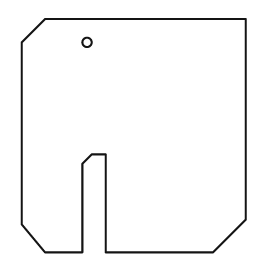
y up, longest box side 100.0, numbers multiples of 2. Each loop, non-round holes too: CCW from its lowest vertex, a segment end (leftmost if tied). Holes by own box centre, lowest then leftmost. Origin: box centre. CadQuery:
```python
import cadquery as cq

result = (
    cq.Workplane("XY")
    .moveTo(-38.0, -50.0)
    .lineTo(-22.0, -50.0)
    .lineTo(-22.0, -12.0)
    .lineTo(-18.0, -8.0)
    .lineTo(-12.0, -8.0)
    .lineTo(-12.0, -50.0)
    .lineTo(34.0, -50.0)
    .lineTo(48.0, -36.0)
    .lineTo(48.0, 50.0)
    .lineTo(-38.0, 50.0)
    .lineTo(-48.0, 40.0)
    .lineTo(-48.0, -38.0)
    .close()
    .moveTo(-20.0, 40.0)
    .circle(2.0)
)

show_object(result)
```